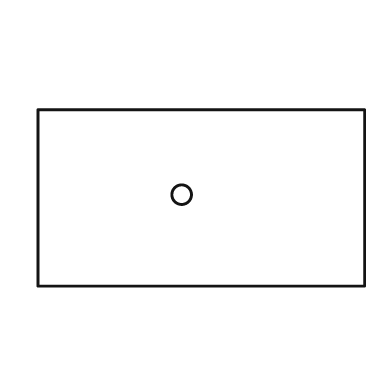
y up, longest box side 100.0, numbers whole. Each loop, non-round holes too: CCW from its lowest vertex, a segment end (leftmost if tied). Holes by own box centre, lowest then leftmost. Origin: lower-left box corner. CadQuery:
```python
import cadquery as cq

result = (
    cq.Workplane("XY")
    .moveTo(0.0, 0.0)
    .lineTo(100.0, 0.0)
    .lineTo(100.0, 54.0)
    .lineTo(0.0, 54.0)
    .close()
    .moveTo(44.0, 28.0)
    .circle(3.0)
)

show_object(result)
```